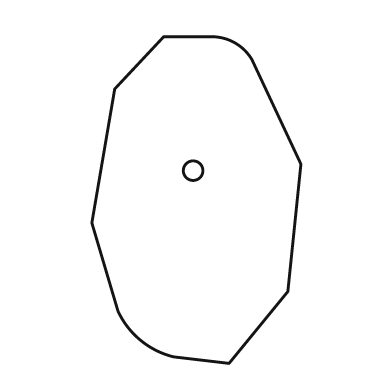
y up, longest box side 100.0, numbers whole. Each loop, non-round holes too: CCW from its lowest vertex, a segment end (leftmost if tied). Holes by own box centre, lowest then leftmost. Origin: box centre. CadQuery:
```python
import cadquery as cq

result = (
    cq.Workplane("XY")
    .moveTo(10.0, -50.0)
    .lineTo(28.0, -28.0)
    .lineTo(32.0, 11.0)
    .lineTo(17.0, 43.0)
    .threePointArc((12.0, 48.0), (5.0, 50.0))
    .lineTo(-10.0, 50.0)
    .lineTo(-25.0, 34.0)
    .lineTo(-32.0, -7.0)
    .lineTo(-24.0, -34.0)
    .threePointArc((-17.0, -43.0), (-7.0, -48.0))
    .close()
    .moveTo(-1.0, 9.0)
    .circle(3.0)
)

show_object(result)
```